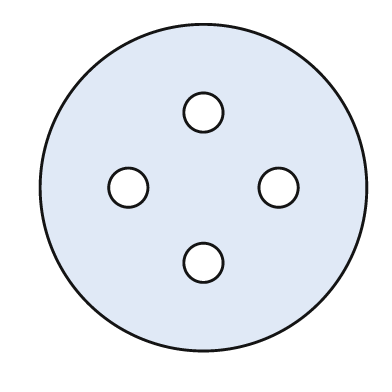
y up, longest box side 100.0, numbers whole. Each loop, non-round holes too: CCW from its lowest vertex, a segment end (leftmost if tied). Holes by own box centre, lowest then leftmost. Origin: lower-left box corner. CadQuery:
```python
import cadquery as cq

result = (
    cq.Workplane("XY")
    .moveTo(50.0, 50.0)
    .circle(50.0)
    .moveTo(50.0, 27.0)
    .circle(6.0)
    .moveTo(27.0, 50.0)
    .circle(6.0)
    .moveTo(73.0, 50.0)
    .circle(6.0)
    .moveTo(50.0, 73.0)
    .circle(6.0)
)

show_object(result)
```